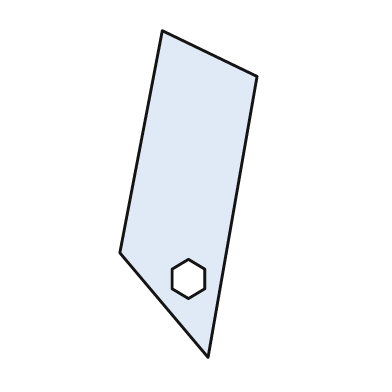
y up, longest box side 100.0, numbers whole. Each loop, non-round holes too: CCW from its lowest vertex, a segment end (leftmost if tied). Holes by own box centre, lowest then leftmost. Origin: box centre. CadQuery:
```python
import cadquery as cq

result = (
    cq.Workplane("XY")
    .moveTo(6.0, -50.0)
    .lineTo(21.0, 36.0)
    .lineTo(-8.0, 50.0)
    .lineTo(-21.0, -18.0)
    .close()
    .moveTo(0.0, -32.0)
    .lineTo(5.0, -29.0)
    .lineTo(5.0, -23.0)
    .lineTo(0.0, -20.0)
    .lineTo(-5.0, -23.0)
    .lineTo(-5.0, -29.0)
    .close()
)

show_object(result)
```